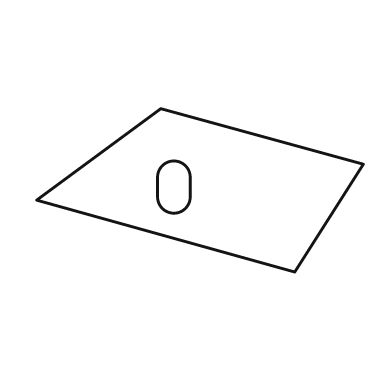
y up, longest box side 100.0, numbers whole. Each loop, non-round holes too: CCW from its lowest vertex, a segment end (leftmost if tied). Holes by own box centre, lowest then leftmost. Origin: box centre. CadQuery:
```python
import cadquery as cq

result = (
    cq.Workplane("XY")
    .moveTo(29.0, -25.0)
    .lineTo(50.0, 8.0)
    .lineTo(-12.0, 25.0)
    .lineTo(-50.0, -3.0)
    .close()
    .moveTo(-13.0, -2.0)
    .threePointArc((-8.0, -7.0), (-3.0, -2.0))
    .lineTo(-3.0, 4.0)
    .threePointArc((-8.0, 9.0), (-13.0, 4.0))
    .close()
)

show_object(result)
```